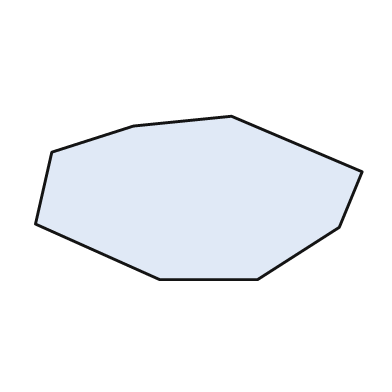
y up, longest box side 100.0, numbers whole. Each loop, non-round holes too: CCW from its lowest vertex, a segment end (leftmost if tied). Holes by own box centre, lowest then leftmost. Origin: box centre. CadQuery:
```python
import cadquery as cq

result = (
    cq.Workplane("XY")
    .moveTo(-12.0, -25.0)
    .lineTo(18.0, -25.0)
    .lineTo(43.0, -9.0)
    .lineTo(50.0, 8.0)
    .lineTo(10.0, 25.0)
    .lineTo(-20.0, 22.0)
    .lineTo(-45.0, 14.0)
    .lineTo(-50.0, -8.0)
    .close()
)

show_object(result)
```